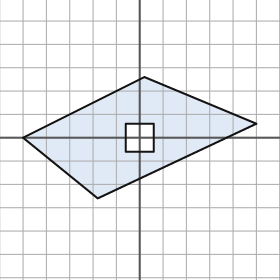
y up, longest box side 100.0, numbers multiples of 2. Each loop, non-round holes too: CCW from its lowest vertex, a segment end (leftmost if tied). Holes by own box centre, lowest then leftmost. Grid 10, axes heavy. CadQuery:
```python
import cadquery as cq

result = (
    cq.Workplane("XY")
    .moveTo(-18.0, -26.0)
    .lineTo(50.0, 6.0)
    .lineTo(2.0, 26.0)
    .lineTo(-50.0, 0.0)
    .close()
    .moveTo(-6.0, -6.0)
    .lineTo(6.0, -6.0)
    .lineTo(6.0, 6.0)
    .lineTo(-6.0, 6.0)
    .close()
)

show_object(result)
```